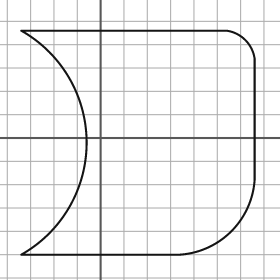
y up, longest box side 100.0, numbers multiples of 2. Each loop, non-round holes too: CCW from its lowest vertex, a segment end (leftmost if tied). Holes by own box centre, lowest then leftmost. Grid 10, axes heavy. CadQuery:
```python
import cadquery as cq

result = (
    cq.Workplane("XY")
    .moveTo(-34.0, -50.0)
    .lineTo(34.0, -50.0)
    .threePointArc((56.0, -40.0), (66.0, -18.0))
    .lineTo(66.0, 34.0)
    .threePointArc((62.0, 42.0), (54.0, 46.0))
    .lineTo(-34.0, 46.0)
    .threePointArc((-6.0, -2.0), (-34.0, -50.0))
    .close()
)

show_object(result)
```